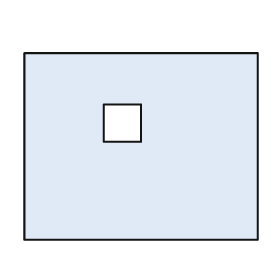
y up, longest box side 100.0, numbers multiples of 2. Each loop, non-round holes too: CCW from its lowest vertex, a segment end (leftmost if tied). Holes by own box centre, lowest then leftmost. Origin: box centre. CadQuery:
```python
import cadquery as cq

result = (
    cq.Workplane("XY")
    .moveTo(-50.0, -40.0)
    .lineTo(50.0, -40.0)
    .lineTo(50.0, 40.0)
    .lineTo(-50.0, 40.0)
    .close()
    .moveTo(-16.0, 2.0)
    .lineTo(0.0, 2.0)
    .lineTo(0.0, 18.0)
    .lineTo(-16.0, 18.0)
    .close()
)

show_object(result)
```